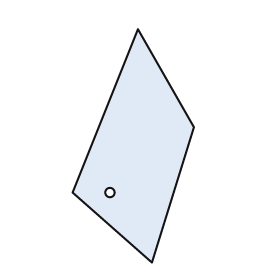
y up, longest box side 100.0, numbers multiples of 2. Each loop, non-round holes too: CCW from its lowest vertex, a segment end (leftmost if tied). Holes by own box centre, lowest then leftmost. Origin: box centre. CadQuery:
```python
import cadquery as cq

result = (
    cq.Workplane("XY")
    .moveTo(8.0, -50.0)
    .lineTo(26.0, 8.0)
    .lineTo(2.0, 50.0)
    .lineTo(-26.0, -20.0)
    .close()
    .moveTo(-10.0, -20.0)
    .circle(2.0)
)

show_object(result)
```